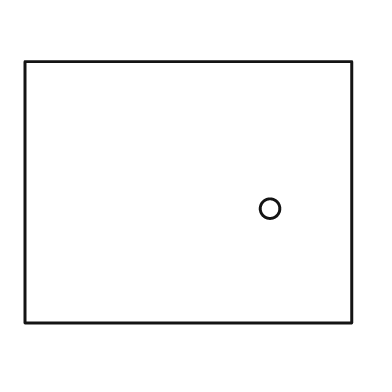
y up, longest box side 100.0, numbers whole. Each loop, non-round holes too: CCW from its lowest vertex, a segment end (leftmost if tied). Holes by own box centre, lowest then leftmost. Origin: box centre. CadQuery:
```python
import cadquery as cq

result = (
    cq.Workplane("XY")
    .moveTo(-50.0, -40.0)
    .lineTo(50.0, -40.0)
    .lineTo(50.0, 40.0)
    .lineTo(-50.0, 40.0)
    .close()
    .moveTo(25.0, -5.0)
    .circle(3.0)
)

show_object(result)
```